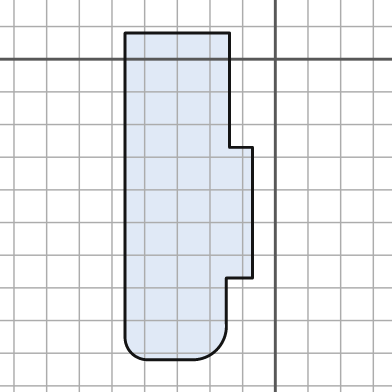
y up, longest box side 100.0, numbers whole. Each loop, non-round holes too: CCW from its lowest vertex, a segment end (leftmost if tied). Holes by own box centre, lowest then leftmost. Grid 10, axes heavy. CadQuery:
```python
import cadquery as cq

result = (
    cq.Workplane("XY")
    .moveTo(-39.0, -92.0)
    .lineTo(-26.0, -92.0)
    .threePointArc((-18.0, -89.0), (-15.0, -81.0))
    .lineTo(-15.0, -67.0)
    .lineTo(-7.0, -67.0)
    .lineTo(-7.0, -27.0)
    .lineTo(-14.0, -27.0)
    .lineTo(-14.0, 8.0)
    .lineTo(-46.0, 8.0)
    .lineTo(-46.0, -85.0)
    .threePointArc((-44.0, -90.0), (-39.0, -92.0))
    .close()
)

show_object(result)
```